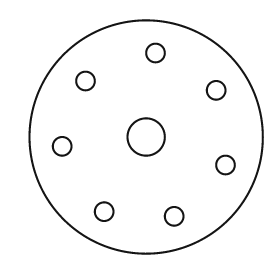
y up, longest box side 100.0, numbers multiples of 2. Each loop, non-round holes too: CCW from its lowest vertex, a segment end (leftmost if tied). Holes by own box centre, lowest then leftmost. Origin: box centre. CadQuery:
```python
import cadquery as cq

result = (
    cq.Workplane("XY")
    .moveTo(0.0, 0.0)
    .circle(50.0)
    .moveTo(12.0, -34.0)
    .circle(4.0)
    .moveTo(-18.0, -32.0)
    .circle(4.0)
    .moveTo(34.0, -12.0)
    .circle(4.0)
    .moveTo(-36.0, -4.0)
    .circle(4.0)
    .moveTo(0.0, 0.0)
    .circle(8.0)
    .moveTo(30.0, 20.0)
    .circle(4.0)
    .moveTo(-26.0, 24.0)
    .circle(4.0)
    .moveTo(4.0, 36.0)
    .circle(4.0)
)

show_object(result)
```